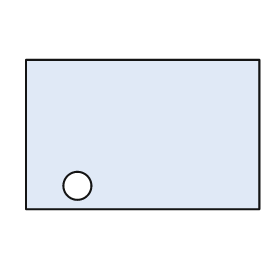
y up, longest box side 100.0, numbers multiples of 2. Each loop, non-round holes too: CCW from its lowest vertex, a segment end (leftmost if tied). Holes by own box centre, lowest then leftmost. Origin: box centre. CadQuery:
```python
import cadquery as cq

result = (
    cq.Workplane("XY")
    .moveTo(-50.0, -32.0)
    .lineTo(50.0, -32.0)
    .lineTo(50.0, 32.0)
    .lineTo(-50.0, 32.0)
    .close()
    .moveTo(-28.0, -22.0)
    .circle(6.0)
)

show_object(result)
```